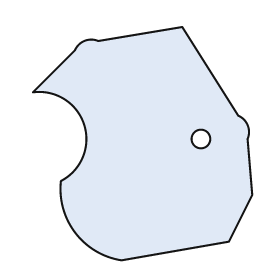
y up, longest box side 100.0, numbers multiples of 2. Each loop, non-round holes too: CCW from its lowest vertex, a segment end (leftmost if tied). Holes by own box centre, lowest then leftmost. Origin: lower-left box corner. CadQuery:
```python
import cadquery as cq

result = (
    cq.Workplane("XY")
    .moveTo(38.0, 0.0)
    .lineTo(84.0, 8.0)
    .lineTo(94.0, 28.0)
    .lineTo(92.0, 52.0)
    .threePointArc((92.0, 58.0), (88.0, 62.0))
    .lineTo(64.0, 100.0)
    .lineTo(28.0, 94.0)
    .threePointArc((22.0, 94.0), (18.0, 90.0))
    .lineTo(0.0, 72.0)
    .threePointArc((22.0, 58.0), (12.0, 34.0))
    .threePointArc((18.0, 12.0), (38.0, 0.0))
    .close()
    .moveTo(72.0, 52.0)
    .circle(4.0)
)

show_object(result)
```